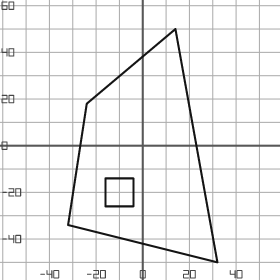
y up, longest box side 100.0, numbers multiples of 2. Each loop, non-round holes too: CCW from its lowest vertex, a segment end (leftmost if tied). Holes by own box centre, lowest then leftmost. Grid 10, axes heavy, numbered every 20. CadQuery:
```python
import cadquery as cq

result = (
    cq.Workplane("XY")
    .moveTo(32.0, -50.0)
    .lineTo(14.0, 50.0)
    .lineTo(-24.0, 18.0)
    .lineTo(-32.0, -34.0)
    .close()
    .moveTo(-16.0, -26.0)
    .lineTo(-4.0, -26.0)
    .lineTo(-4.0, -14.0)
    .lineTo(-16.0, -14.0)
    .close()
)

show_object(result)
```